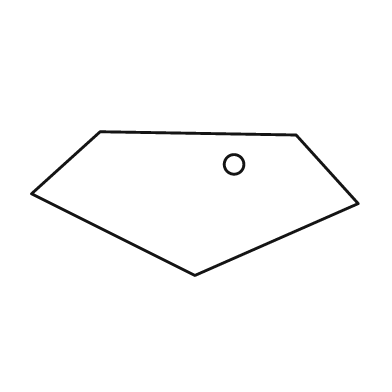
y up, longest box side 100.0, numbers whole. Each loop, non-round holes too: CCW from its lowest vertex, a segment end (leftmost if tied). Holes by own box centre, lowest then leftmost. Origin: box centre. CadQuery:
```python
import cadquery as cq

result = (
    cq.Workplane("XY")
    .moveTo(0.0, -22.0)
    .lineTo(50.0, 0.0)
    .lineTo(31.0, 21.0)
    .lineTo(-29.0, 22.0)
    .lineTo(-50.0, 3.0)
    .close()
    .moveTo(12.0, 12.0)
    .circle(3.0)
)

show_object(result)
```